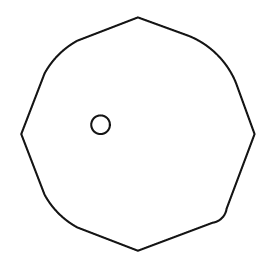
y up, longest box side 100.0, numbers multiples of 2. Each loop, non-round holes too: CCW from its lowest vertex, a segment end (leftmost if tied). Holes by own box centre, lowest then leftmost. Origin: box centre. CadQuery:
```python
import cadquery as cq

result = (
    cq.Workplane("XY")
    .moveTo(0.0, -50.0)
    .lineTo(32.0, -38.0)
    .threePointArc((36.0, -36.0), (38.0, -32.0))
    .lineTo(50.0, 0.0)
    .lineTo(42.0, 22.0)
    .threePointArc((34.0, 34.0), (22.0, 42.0))
    .lineTo(0.0, 50.0)
    .lineTo(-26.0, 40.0)
    .threePointArc((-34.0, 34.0), (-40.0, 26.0))
    .lineTo(-50.0, 0.0)
    .lineTo(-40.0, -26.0)
    .threePointArc((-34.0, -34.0), (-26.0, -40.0))
    .close()
    .moveTo(-16.0, 4.0)
    .circle(4.0)
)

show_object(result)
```